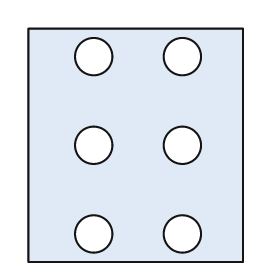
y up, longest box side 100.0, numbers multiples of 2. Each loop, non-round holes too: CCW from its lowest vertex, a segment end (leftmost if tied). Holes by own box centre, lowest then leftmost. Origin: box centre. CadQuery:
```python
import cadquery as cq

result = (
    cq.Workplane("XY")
    .moveTo(-46.0, -50.0)
    .lineTo(46.0, -50.0)
    .lineTo(46.0, 50.0)
    .lineTo(-46.0, 50.0)
    .close()
    .moveTo(-18.0, -38.0)
    .circle(8.0)
    .moveTo(20.0, -38.0)
    .circle(8.0)
    .moveTo(-18.0, 0.0)
    .circle(8.0)
    .moveTo(20.0, 0.0)
    .circle(8.0)
    .moveTo(-18.0, 38.0)
    .circle(8.0)
    .moveTo(20.0, 38.0)
    .circle(8.0)
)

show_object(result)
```